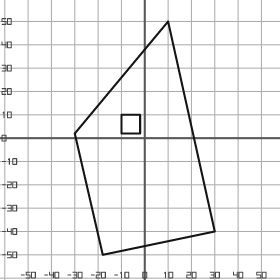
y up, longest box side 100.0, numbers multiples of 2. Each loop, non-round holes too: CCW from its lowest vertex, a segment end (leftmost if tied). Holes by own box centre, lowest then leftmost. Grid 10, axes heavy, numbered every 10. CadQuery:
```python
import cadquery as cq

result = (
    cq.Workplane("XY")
    .moveTo(-18.0, -50.0)
    .lineTo(30.0, -40.0)
    .lineTo(10.0, 50.0)
    .lineTo(-30.0, 2.0)
    .close()
    .moveTo(-10.0, 2.0)
    .lineTo(-2.0, 2.0)
    .lineTo(-2.0, 10.0)
    .lineTo(-10.0, 10.0)
    .close()
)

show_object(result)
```